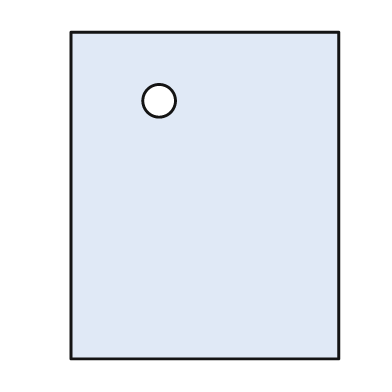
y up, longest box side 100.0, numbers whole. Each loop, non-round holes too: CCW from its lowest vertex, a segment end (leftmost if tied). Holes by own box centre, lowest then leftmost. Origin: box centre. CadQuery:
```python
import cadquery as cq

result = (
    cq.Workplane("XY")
    .moveTo(-41.0, -50.0)
    .lineTo(41.0, -50.0)
    .lineTo(41.0, 50.0)
    .lineTo(-41.0, 50.0)
    .close()
    .moveTo(-14.0, 29.0)
    .circle(5.0)
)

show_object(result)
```